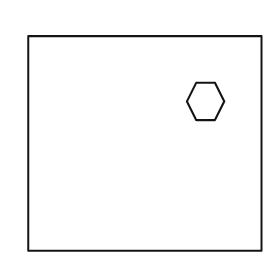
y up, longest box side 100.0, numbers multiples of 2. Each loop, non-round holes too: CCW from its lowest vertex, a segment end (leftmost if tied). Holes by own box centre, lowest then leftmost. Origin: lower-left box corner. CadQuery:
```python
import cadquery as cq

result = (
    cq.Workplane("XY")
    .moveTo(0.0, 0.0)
    .lineTo(100.0, 0.0)
    .lineTo(100.0, 92.0)
    .lineTo(0.0, 92.0)
    .close()
    .moveTo(72.0, 56.0)
    .lineTo(80.0, 56.0)
    .lineTo(84.0, 64.0)
    .lineTo(80.0, 72.0)
    .lineTo(72.0, 72.0)
    .lineTo(68.0, 64.0)
    .close()
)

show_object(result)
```